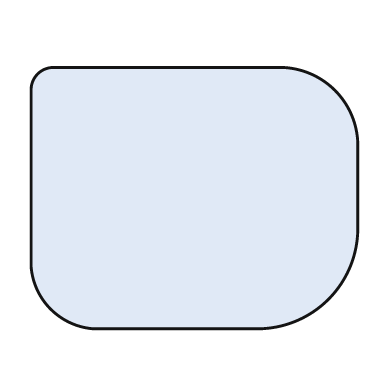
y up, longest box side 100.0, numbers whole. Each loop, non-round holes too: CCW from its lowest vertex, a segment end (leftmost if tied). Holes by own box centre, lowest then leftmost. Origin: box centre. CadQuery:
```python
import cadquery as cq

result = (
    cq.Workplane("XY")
    .moveTo(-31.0, -40.0)
    .lineTo(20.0, -40.0)
    .threePointArc((41.0, -31.0), (50.0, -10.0))
    .lineTo(50.0, 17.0)
    .threePointArc((43.0, 33.0), (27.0, 40.0))
    .lineTo(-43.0, 40.0)
    .threePointArc((-48.0, 38.0), (-50.0, 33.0))
    .lineTo(-50.0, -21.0)
    .threePointArc((-44.0, -34.0), (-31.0, -40.0))
    .close()
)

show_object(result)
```